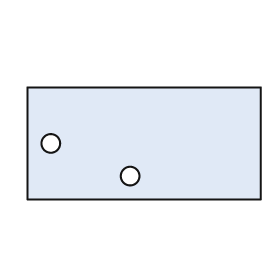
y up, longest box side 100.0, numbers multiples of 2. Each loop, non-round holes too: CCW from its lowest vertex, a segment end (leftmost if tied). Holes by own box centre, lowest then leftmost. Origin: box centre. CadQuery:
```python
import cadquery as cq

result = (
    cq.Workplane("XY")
    .moveTo(-50.0, -24.0)
    .lineTo(50.0, -24.0)
    .lineTo(50.0, 24.0)
    .lineTo(-50.0, 24.0)
    .close()
    .moveTo(-6.0, -14.0)
    .circle(4.0)
    .moveTo(-40.0, 0.0)
    .circle(4.0)
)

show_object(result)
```